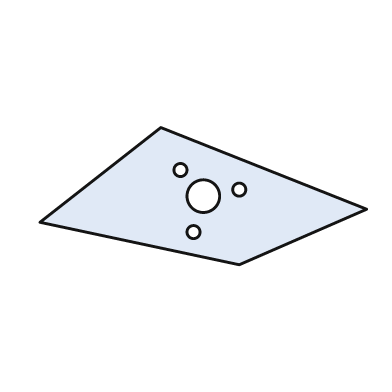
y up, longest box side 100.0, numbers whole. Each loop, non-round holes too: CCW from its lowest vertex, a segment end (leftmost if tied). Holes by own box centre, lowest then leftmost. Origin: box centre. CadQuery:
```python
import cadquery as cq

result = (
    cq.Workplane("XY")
    .moveTo(11.0, -21.0)
    .lineTo(50.0, -4.0)
    .lineTo(-13.0, 21.0)
    .lineTo(-50.0, -8.0)
    .close()
    .moveTo(-3.0, -11.0)
    .circle(2.0)
    .moveTo(0.0, 0.0)
    .circle(5.0)
    .moveTo(11.0, 2.0)
    .circle(2.0)
    .moveTo(-7.0, 8.0)
    .circle(2.0)
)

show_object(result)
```